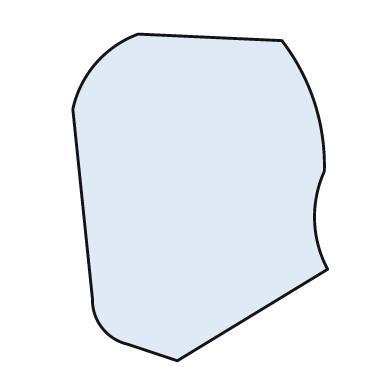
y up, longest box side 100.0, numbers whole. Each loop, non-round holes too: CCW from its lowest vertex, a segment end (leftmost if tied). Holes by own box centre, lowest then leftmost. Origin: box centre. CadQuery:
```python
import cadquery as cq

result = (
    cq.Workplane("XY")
    .moveTo(-7.0, -50.0)
    .lineTo(39.0, -22.0)
    .threePointArc((35.0, -7.0), (38.0, 8.0))
    .threePointArc((35.0, 29.0), (25.0, 48.0))
    .lineTo(-19.0, 50.0)
    .threePointArc((-32.0, 41.0), (-39.0, 27.0))
    .lineTo(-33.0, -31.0)
    .threePointArc((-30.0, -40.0), (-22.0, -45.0))
    .close()
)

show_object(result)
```